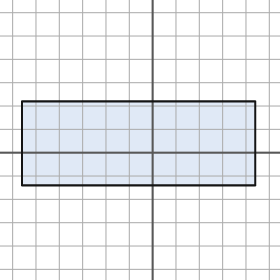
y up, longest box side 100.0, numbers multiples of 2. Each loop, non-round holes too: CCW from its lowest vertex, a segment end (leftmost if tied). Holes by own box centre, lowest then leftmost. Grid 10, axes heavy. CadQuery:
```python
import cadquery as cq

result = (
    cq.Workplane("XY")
    .moveTo(-56.0, -14.0)
    .lineTo(44.0, -14.0)
    .lineTo(44.0, 22.0)
    .lineTo(-56.0, 22.0)
    .close()
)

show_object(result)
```